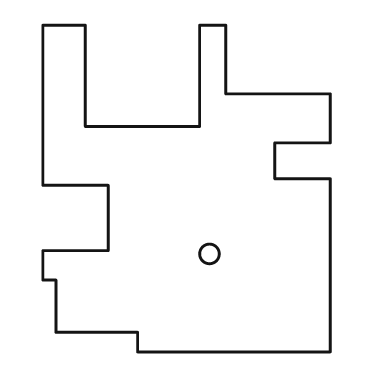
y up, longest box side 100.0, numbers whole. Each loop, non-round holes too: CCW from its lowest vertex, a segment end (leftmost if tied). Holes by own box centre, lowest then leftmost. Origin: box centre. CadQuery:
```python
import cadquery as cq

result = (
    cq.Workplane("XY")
    .moveTo(-15.0, -50.0)
    .lineTo(44.0, -50.0)
    .lineTo(44.0, 3.0)
    .lineTo(27.0, 3.0)
    .lineTo(27.0, 14.0)
    .lineTo(44.0, 14.0)
    .lineTo(44.0, 29.0)
    .lineTo(12.0, 29.0)
    .lineTo(12.0, 50.0)
    .lineTo(4.0, 50.0)
    .lineTo(4.0, 19.0)
    .lineTo(-31.0, 19.0)
    .lineTo(-31.0, 50.0)
    .lineTo(-44.0, 50.0)
    .lineTo(-44.0, 1.0)
    .lineTo(-24.0, 1.0)
    .lineTo(-24.0, -19.0)
    .lineTo(-44.0, -19.0)
    .lineTo(-44.0, -28.0)
    .lineTo(-40.0, -28.0)
    .lineTo(-40.0, -44.0)
    .lineTo(-15.0, -44.0)
    .close()
    .moveTo(7.0, -20.0)
    .circle(3.0)
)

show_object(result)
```